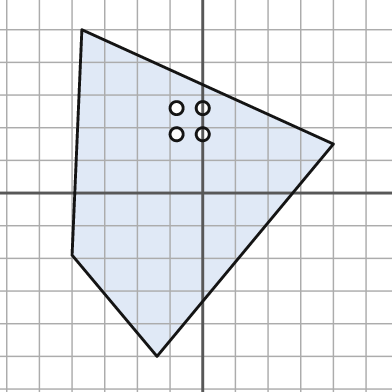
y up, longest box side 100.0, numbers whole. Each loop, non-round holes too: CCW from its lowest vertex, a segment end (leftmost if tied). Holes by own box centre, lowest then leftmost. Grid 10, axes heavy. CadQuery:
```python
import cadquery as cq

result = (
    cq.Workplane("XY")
    .moveTo(-14.0, -50.0)
    .lineTo(40.0, 15.0)
    .lineTo(-37.0, 50.0)
    .lineTo(-40.0, -19.0)
    .close()
    .moveTo(-8.0, 18.0)
    .circle(2.0)
    .moveTo(0.0, 18.0)
    .circle(2.0)
    .moveTo(-8.0, 26.0)
    .circle(2.0)
    .moveTo(0.0, 26.0)
    .circle(2.0)
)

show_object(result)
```